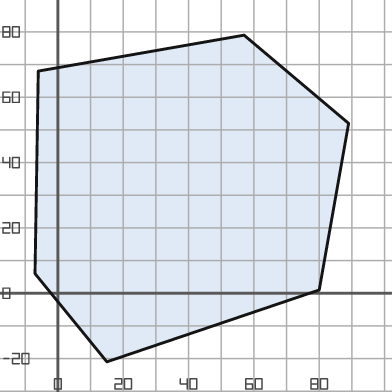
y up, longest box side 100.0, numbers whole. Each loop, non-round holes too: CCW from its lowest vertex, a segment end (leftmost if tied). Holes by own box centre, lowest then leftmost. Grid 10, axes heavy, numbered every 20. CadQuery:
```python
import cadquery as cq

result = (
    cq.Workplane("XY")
    .moveTo(15.0, -21.0)
    .lineTo(80.0, 1.0)
    .lineTo(89.0, 52.0)
    .lineTo(57.0, 79.0)
    .lineTo(-6.0, 68.0)
    .lineTo(-7.0, 6.0)
    .close()
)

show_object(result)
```